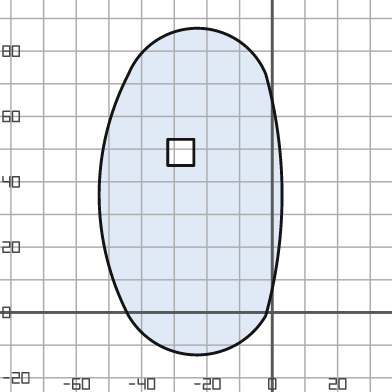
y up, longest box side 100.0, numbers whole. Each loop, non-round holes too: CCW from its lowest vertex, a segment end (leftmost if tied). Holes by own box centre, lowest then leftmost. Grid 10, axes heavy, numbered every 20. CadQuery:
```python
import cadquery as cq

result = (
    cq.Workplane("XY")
    .moveTo(-44.0, -1.0)
    .threePointArc((-23.0, -13.0), (-2.0, -1.0))
    .threePointArc((3.0, 36.0), (-2.0, 73.0))
    .threePointArc((-23.0, 87.0), (-44.0, 73.0))
    .threePointArc((-53.0, 36.0), (-44.0, -1.0))
    .close()
    .moveTo(-32.0, 45.0)
    .lineTo(-24.0, 45.0)
    .lineTo(-24.0, 53.0)
    .lineTo(-32.0, 53.0)
    .close()
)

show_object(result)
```